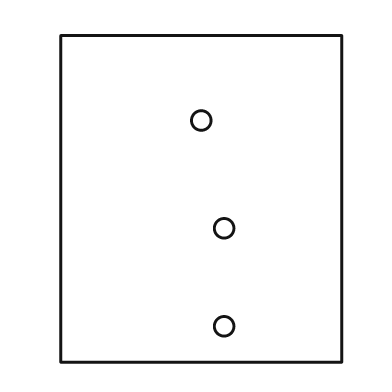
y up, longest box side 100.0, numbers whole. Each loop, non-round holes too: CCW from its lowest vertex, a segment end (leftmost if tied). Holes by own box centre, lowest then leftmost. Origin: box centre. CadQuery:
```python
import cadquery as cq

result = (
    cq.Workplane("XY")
    .moveTo(-43.0, -50.0)
    .lineTo(43.0, -50.0)
    .lineTo(43.0, 50.0)
    .lineTo(-43.0, 50.0)
    .close()
    .moveTo(7.0, -39.0)
    .circle(3.0)
    .moveTo(7.0, -9.0)
    .circle(3.0)
    .moveTo(0.0, 24.0)
    .circle(3.0)
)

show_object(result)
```